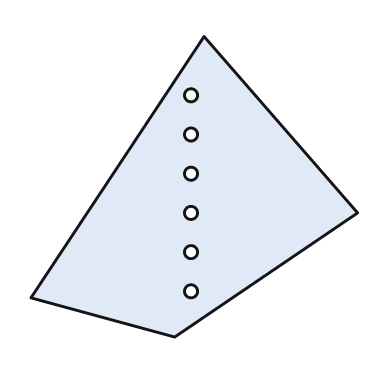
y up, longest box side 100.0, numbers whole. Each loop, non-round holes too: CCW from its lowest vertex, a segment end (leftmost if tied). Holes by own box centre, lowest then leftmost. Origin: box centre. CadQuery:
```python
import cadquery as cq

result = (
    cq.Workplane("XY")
    .moveTo(-6.0, -46.0)
    .lineTo(50.0, -8.0)
    .lineTo(3.0, 46.0)
    .lineTo(-50.0, -34.0)
    .close()
    .moveTo(-1.0, -32.0)
    .circle(2.0)
    .moveTo(-1.0, -20.0)
    .circle(2.0)
    .moveTo(-1.0, -8.0)
    .circle(2.0)
    .moveTo(-1.0, 4.0)
    .circle(2.0)
    .moveTo(-1.0, 16.0)
    .circle(2.0)
    .moveTo(-1.0, 28.0)
    .circle(2.0)
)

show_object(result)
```